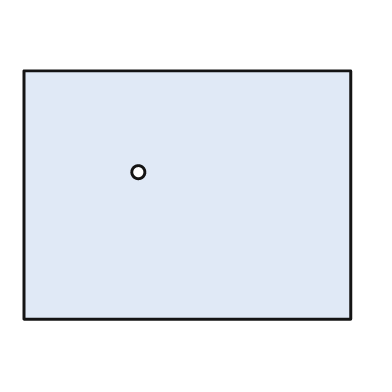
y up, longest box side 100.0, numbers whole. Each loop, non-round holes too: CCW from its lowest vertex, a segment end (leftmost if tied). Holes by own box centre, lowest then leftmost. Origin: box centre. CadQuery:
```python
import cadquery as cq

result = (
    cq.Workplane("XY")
    .moveTo(-50.0, -38.0)
    .lineTo(50.0, -38.0)
    .lineTo(50.0, 38.0)
    .lineTo(-50.0, 38.0)
    .close()
    .moveTo(-15.0, 7.0)
    .circle(2.0)
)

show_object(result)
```